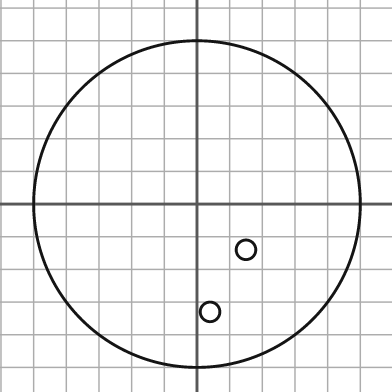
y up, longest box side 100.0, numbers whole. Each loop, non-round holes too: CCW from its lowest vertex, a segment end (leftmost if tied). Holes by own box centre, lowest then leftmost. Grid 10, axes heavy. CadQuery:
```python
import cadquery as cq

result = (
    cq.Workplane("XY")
    .moveTo(0.0, 0.0)
    .circle(50.0)
    .moveTo(4.0, -33.0)
    .circle(3.0)
    .moveTo(15.0, -14.0)
    .circle(3.0)
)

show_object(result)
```